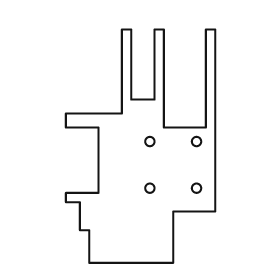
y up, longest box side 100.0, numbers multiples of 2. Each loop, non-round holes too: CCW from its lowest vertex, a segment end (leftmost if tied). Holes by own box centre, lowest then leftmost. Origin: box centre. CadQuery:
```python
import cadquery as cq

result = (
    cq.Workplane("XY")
    .moveTo(-22.0, -50.0)
    .lineTo(14.0, -50.0)
    .lineTo(14.0, -28.0)
    .lineTo(32.0, -28.0)
    .lineTo(32.0, 50.0)
    .lineTo(28.0, 50.0)
    .lineTo(28.0, 8.0)
    .lineTo(10.0, 8.0)
    .lineTo(10.0, 50.0)
    .lineTo(6.0, 50.0)
    .lineTo(6.0, 20.0)
    .lineTo(-4.0, 20.0)
    .lineTo(-4.0, 50.0)
    .lineTo(-8.0, 50.0)
    .lineTo(-8.0, 14.0)
    .lineTo(-32.0, 14.0)
    .lineTo(-32.0, 8.0)
    .lineTo(-18.0, 8.0)
    .lineTo(-18.0, -20.0)
    .lineTo(-32.0, -20.0)
    .lineTo(-32.0, -24.0)
    .lineTo(-26.0, -24.0)
    .lineTo(-26.0, -36.0)
    .lineTo(-22.0, -36.0)
    .close()
    .moveTo(4.0, -18.0)
    .circle(2.0)
    .moveTo(24.0, -18.0)
    .circle(2.0)
    .moveTo(4.0, 2.0)
    .circle(2.0)
    .moveTo(24.0, 2.0)
    .circle(2.0)
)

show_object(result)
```